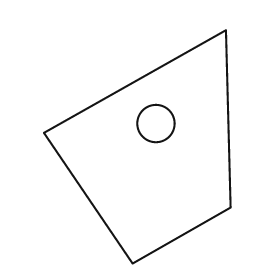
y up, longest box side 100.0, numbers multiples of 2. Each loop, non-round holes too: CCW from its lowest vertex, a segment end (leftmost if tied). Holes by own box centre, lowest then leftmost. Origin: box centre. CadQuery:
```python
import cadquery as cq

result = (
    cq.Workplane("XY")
    .moveTo(-2.0, -50.0)
    .lineTo(40.0, -26.0)
    .lineTo(38.0, 50.0)
    .lineTo(-40.0, 6.0)
    .close()
    .moveTo(8.0, 10.0)
    .circle(8.0)
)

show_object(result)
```